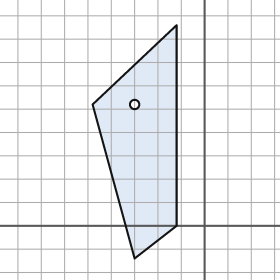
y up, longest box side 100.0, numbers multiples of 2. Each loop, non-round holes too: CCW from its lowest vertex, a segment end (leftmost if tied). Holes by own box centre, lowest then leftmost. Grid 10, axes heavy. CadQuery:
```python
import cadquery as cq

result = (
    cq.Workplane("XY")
    .moveTo(-30.0, -14.0)
    .lineTo(-12.0, 0.0)
    .lineTo(-12.0, 86.0)
    .lineTo(-48.0, 52.0)
    .close()
    .moveTo(-30.0, 52.0)
    .circle(2.0)
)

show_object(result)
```